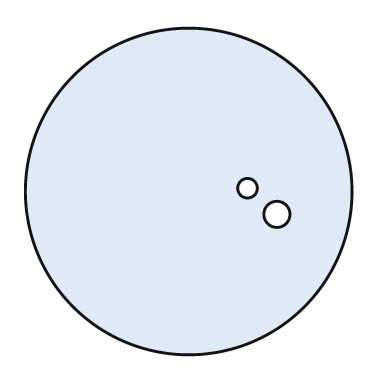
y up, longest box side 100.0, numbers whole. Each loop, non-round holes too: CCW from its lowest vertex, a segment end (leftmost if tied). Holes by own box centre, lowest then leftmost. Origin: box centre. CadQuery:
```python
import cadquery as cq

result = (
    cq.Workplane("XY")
    .moveTo(0.0, 0.0)
    .circle(50.0)
    .moveTo(27.0, -7.0)
    .circle(4.0)
    .moveTo(18.0, 1.0)
    .circle(3.0)
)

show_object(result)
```